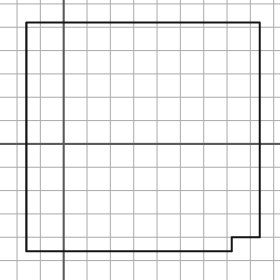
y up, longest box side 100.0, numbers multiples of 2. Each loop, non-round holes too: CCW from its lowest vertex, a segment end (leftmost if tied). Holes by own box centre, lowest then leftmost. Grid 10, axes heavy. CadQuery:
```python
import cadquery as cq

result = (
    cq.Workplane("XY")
    .moveTo(-16.0, -46.0)
    .lineTo(72.0, -46.0)
    .lineTo(72.0, -40.0)
    .lineTo(84.0, -40.0)
    .lineTo(84.0, 52.0)
    .lineTo(-16.0, 52.0)
    .close()
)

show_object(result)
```